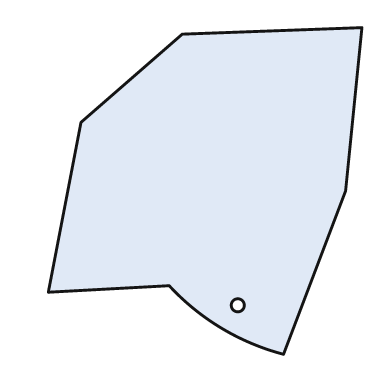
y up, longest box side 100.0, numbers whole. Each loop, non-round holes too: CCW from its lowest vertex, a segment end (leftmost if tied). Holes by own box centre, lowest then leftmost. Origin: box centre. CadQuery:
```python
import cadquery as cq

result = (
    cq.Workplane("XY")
    .moveTo(24.0, -50.0)
    .lineTo(43.0, 0.0)
    .lineTo(48.0, 50.0)
    .lineTo(-7.0, 48.0)
    .lineTo(-38.0, 21.0)
    .lineTo(-48.0, -31.0)
    .lineTo(-11.0, -29.0)
    .threePointArc((5.0, -42.0), (24.0, -50.0))
    .close()
    .moveTo(10.0, -35.0)
    .circle(2.0)
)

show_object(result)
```